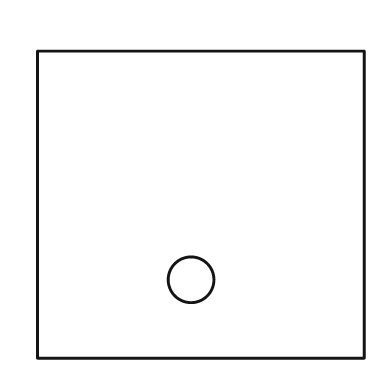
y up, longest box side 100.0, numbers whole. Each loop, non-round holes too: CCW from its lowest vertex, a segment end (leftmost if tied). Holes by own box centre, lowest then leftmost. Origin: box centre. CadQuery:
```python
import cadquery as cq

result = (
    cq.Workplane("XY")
    .moveTo(-50.0, -47.0)
    .lineTo(50.0, -47.0)
    .lineTo(50.0, 47.0)
    .lineTo(-50.0, 47.0)
    .close()
    .moveTo(-3.0, -23.0)
    .circle(7.0)
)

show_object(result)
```